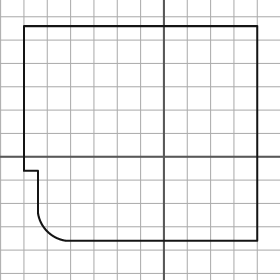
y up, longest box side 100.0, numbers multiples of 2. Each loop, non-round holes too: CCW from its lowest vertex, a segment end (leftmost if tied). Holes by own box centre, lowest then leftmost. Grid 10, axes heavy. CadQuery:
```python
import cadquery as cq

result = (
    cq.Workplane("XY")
    .moveTo(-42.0, -36.0)
    .lineTo(40.0, -36.0)
    .lineTo(40.0, 56.0)
    .lineTo(-60.0, 56.0)
    .lineTo(-60.0, -6.0)
    .lineTo(-54.0, -6.0)
    .lineTo(-54.0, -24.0)
    .threePointArc((-50.0, -32.0), (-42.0, -36.0))
    .close()
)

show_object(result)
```